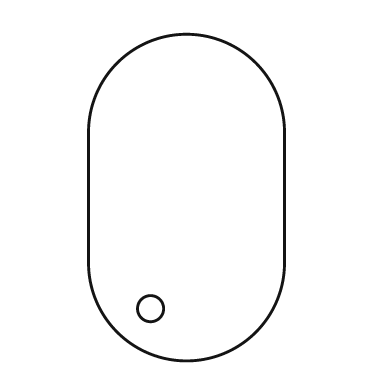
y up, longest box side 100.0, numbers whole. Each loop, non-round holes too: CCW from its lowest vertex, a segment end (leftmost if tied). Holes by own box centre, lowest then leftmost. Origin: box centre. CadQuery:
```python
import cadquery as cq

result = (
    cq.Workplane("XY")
    .moveTo(-30.0, -20.0)
    .threePointArc((0.0, -50.0), (30.0, -20.0))
    .lineTo(30.0, 20.0)
    .threePointArc((0.0, 50.0), (-30.0, 20.0))
    .close()
    .moveTo(-11.0, -34.0)
    .circle(4.0)
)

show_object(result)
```